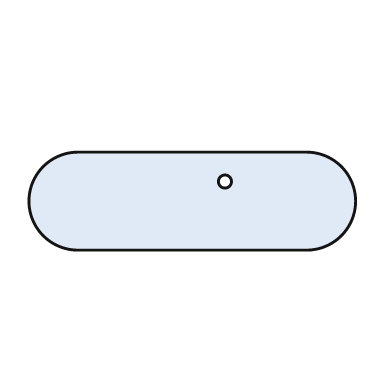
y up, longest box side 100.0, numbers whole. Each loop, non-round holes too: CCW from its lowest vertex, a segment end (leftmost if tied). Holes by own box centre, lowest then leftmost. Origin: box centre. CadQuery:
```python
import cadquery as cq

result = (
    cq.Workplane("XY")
    .moveTo(-35.0, -15.0)
    .lineTo(35.0, -15.0)
    .threePointArc((50.0, 0.0), (35.0, 15.0))
    .lineTo(-35.0, 15.0)
    .threePointArc((-50.0, 0.0), (-35.0, -15.0))
    .close()
    .moveTo(10.0, 6.0)
    .circle(2.0)
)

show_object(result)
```